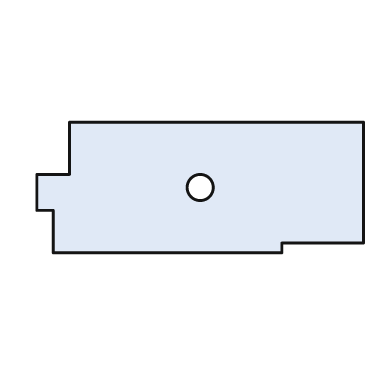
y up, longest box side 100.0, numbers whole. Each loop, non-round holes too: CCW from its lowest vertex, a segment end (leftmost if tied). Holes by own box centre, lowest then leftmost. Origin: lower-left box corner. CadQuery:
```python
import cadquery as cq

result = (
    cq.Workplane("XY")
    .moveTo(5.0, 0.0)
    .lineTo(75.0, 0.0)
    .lineTo(75.0, 3.0)
    .lineTo(100.0, 3.0)
    .lineTo(100.0, 40.0)
    .lineTo(10.0, 40.0)
    .lineTo(10.0, 24.0)
    .lineTo(0.0, 24.0)
    .lineTo(0.0, 13.0)
    .lineTo(5.0, 13.0)
    .close()
    .moveTo(50.0, 20.0)
    .circle(4.0)
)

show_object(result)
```